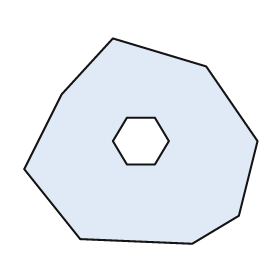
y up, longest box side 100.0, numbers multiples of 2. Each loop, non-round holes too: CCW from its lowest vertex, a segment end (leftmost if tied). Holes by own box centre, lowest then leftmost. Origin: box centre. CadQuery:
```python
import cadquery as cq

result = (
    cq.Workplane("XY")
    .moveTo(22.0, -44.0)
    .lineTo(42.0, -32.0)
    .lineTo(50.0, 0.0)
    .lineTo(28.0, 32.0)
    .lineTo(-12.0, 44.0)
    .lineTo(-34.0, 20.0)
    .lineTo(-50.0, -12.0)
    .lineTo(-26.0, -42.0)
    .close()
    .moveTo(-6.0, -10.0)
    .lineTo(6.0, -10.0)
    .lineTo(12.0, 0.0)
    .lineTo(6.0, 10.0)
    .lineTo(-6.0, 10.0)
    .lineTo(-12.0, 0.0)
    .close()
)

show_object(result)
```